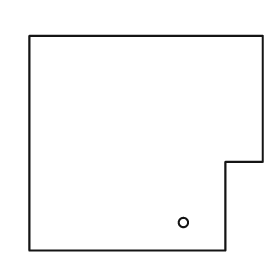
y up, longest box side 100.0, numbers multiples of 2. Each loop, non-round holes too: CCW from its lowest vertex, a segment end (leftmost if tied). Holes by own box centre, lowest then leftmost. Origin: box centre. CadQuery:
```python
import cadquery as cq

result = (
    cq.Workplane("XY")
    .moveTo(-50.0, -46.0)
    .lineTo(34.0, -46.0)
    .lineTo(34.0, -8.0)
    .lineTo(50.0, -8.0)
    .lineTo(50.0, 46.0)
    .lineTo(-50.0, 46.0)
    .close()
    .moveTo(16.0, -34.0)
    .circle(2.0)
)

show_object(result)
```